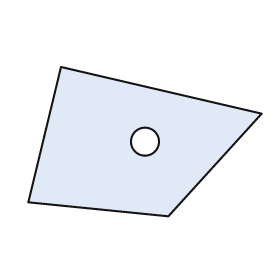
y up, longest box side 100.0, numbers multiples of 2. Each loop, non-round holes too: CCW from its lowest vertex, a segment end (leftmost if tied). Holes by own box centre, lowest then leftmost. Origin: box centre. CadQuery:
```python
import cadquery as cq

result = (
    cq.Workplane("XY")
    .moveTo(10.0, -32.0)
    .lineTo(50.0, 12.0)
    .lineTo(-36.0, 32.0)
    .lineTo(-50.0, -26.0)
    .close()
    .moveTo(0.0, 0.0)
    .circle(6.0)
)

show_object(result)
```